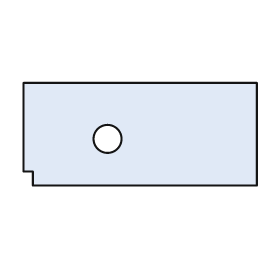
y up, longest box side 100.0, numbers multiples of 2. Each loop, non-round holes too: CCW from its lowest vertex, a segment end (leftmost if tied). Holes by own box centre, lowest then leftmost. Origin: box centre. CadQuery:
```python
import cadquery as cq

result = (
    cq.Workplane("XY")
    .moveTo(-46.0, -22.0)
    .lineTo(50.0, -22.0)
    .lineTo(50.0, 22.0)
    .lineTo(-50.0, 22.0)
    .lineTo(-50.0, -16.0)
    .lineTo(-46.0, -16.0)
    .close()
    .moveTo(-14.0, -2.0)
    .circle(6.0)
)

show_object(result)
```